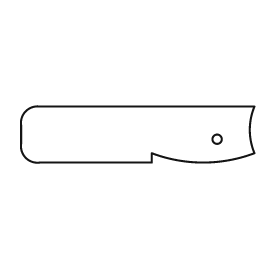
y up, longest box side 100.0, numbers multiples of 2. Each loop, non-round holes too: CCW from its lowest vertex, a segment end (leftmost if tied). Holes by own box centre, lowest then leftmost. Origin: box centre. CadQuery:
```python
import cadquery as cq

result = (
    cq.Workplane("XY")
    .moveTo(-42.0, -12.0)
    .lineTo(6.0, -12.0)
    .lineTo(6.0, -8.0)
    .threePointArc((28.0, -12.0), (50.0, -8.0))
    .threePointArc((48.0, 2.0), (50.0, 12.0))
    .lineTo(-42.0, 12.0)
    .threePointArc((-48.0, 10.0), (-50.0, 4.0))
    .lineTo(-50.0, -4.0)
    .threePointArc((-48.0, -10.0), (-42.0, -12.0))
    .close()
    .moveTo(34.0, -2.0)
    .circle(2.0)
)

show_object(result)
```